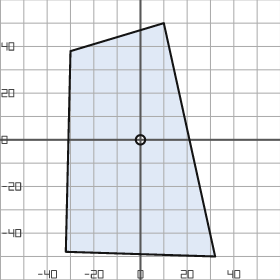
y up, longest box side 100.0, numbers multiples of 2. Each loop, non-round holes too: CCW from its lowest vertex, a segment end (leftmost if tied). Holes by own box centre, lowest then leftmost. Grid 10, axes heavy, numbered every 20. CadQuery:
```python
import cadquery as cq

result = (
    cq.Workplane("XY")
    .moveTo(32.0, -50.0)
    .lineTo(10.0, 50.0)
    .lineTo(-30.0, 38.0)
    .lineTo(-32.0, -48.0)
    .close()
    .moveTo(0.0, 0.0)
    .circle(2.0)
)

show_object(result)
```